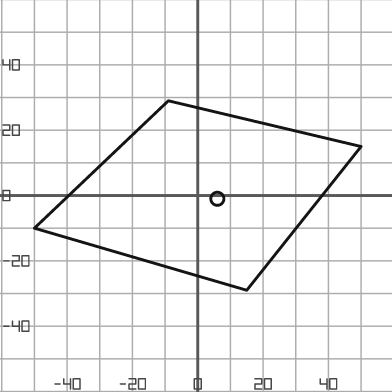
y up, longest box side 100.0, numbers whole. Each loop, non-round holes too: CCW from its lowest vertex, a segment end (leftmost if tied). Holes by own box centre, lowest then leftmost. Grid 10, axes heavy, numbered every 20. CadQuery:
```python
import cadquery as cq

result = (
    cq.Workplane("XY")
    .moveTo(15.0, -29.0)
    .lineTo(50.0, 15.0)
    .lineTo(-9.0, 29.0)
    .lineTo(-50.0, -10.0)
    .close()
    .moveTo(6.0, -1.0)
    .circle(2.0)
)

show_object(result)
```